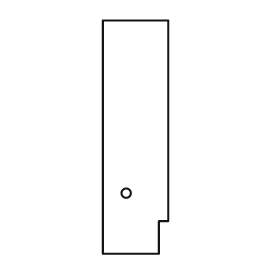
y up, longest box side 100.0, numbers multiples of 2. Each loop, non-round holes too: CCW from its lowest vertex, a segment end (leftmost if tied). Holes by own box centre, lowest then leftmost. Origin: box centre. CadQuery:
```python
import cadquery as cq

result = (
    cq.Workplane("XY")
    .moveTo(-14.0, -50.0)
    .lineTo(10.0, -50.0)
    .lineTo(10.0, -36.0)
    .lineTo(14.0, -36.0)
    .lineTo(14.0, 50.0)
    .lineTo(-14.0, 50.0)
    .close()
    .moveTo(-4.0, -24.0)
    .circle(2.0)
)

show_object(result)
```